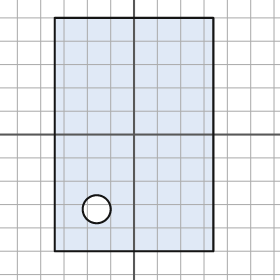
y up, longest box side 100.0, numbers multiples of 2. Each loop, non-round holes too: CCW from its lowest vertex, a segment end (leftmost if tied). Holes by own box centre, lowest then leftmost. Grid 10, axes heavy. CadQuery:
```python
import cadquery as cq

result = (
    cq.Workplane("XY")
    .moveTo(-34.0, -50.0)
    .lineTo(34.0, -50.0)
    .lineTo(34.0, 50.0)
    .lineTo(-34.0, 50.0)
    .close()
    .moveTo(-16.0, -32.0)
    .circle(6.0)
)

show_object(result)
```